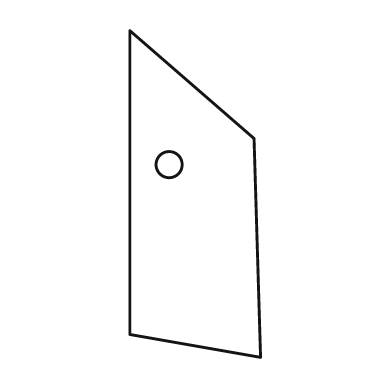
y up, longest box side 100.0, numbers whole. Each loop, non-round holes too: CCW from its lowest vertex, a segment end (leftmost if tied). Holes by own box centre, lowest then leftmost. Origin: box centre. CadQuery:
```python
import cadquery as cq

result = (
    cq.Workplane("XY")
    .moveTo(20.0, -50.0)
    .lineTo(18.0, 17.0)
    .lineTo(-20.0, 50.0)
    .lineTo(-20.0, -43.0)
    .close()
    .moveTo(-8.0, 9.0)
    .circle(4.0)
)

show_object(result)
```